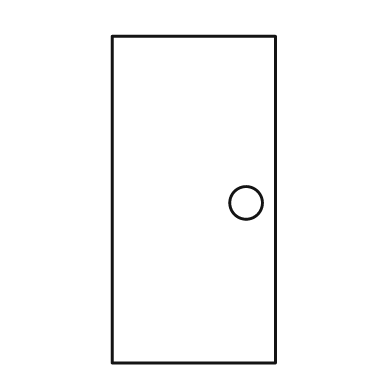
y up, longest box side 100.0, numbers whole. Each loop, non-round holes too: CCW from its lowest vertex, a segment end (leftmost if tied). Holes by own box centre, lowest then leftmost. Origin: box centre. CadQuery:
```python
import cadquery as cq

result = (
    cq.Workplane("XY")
    .moveTo(-25.0, -50.0)
    .lineTo(25.0, -50.0)
    .lineTo(25.0, 50.0)
    .lineTo(-25.0, 50.0)
    .close()
    .moveTo(16.0, -1.0)
    .circle(5.0)
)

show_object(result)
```